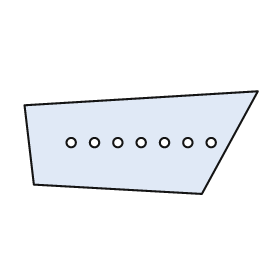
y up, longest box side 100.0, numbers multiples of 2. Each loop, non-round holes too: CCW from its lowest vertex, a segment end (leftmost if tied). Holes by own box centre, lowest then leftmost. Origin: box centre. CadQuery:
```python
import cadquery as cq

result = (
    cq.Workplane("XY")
    .moveTo(26.0, -22.0)
    .lineTo(50.0, 22.0)
    .lineTo(-50.0, 16.0)
    .lineTo(-46.0, -18.0)
    .close()
    .moveTo(-30.0, 0.0)
    .circle(2.0)
    .moveTo(-20.0, 0.0)
    .circle(2.0)
    .moveTo(-10.0, 0.0)
    .circle(2.0)
    .moveTo(0.0, 0.0)
    .circle(2.0)
    .moveTo(10.0, 0.0)
    .circle(2.0)
    .moveTo(20.0, 0.0)
    .circle(2.0)
    .moveTo(30.0, 0.0)
    .circle(2.0)
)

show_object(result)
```